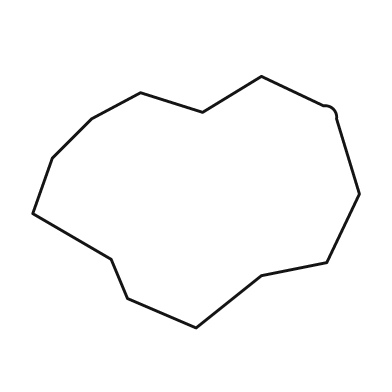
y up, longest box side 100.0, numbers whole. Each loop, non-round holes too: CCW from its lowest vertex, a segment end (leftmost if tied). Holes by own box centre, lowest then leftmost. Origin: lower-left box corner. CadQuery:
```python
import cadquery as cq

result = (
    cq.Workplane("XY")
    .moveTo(50.0, 0.0)
    .lineTo(70.0, 16.0)
    .lineTo(90.0, 20.0)
    .lineTo(100.0, 41.0)
    .lineTo(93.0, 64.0)
    .threePointArc((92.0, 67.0), (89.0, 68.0))
    .lineTo(70.0, 77.0)
    .lineTo(52.0, 66.0)
    .lineTo(33.0, 72.0)
    .lineTo(18.0, 64.0)
    .lineTo(6.0, 52.0)
    .lineTo(0.0, 35.0)
    .lineTo(24.0, 21.0)
    .lineTo(29.0, 9.0)
    .close()
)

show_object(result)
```